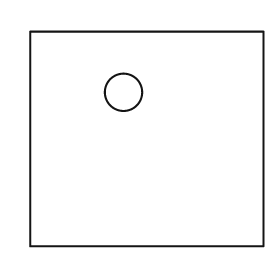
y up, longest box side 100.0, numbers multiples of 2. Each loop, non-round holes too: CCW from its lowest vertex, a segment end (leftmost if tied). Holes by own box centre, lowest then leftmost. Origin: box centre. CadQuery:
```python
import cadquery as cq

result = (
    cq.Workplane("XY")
    .moveTo(-50.0, -46.0)
    .lineTo(50.0, -46.0)
    .lineTo(50.0, 46.0)
    .lineTo(-50.0, 46.0)
    .close()
    .moveTo(-10.0, 20.0)
    .circle(8.0)
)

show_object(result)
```